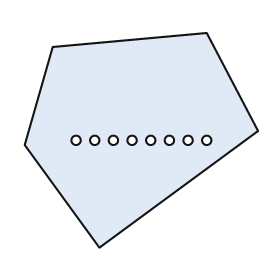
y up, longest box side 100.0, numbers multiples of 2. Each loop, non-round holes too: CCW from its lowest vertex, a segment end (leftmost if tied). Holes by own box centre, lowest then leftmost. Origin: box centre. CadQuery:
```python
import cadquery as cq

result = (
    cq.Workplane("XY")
    .moveTo(-18.0, -46.0)
    .lineTo(50.0, 4.0)
    .lineTo(28.0, 46.0)
    .lineTo(-38.0, 40.0)
    .lineTo(-50.0, -2.0)
    .close()
    .moveTo(-28.0, 0.0)
    .circle(2.0)
    .moveTo(-20.0, 0.0)
    .circle(2.0)
    .moveTo(-12.0, 0.0)
    .circle(2.0)
    .moveTo(-4.0, 0.0)
    .circle(2.0)
    .moveTo(4.0, 0.0)
    .circle(2.0)
    .moveTo(12.0, 0.0)
    .circle(2.0)
    .moveTo(20.0, 0.0)
    .circle(2.0)
    .moveTo(28.0, 0.0)
    .circle(2.0)
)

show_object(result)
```